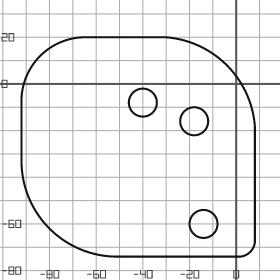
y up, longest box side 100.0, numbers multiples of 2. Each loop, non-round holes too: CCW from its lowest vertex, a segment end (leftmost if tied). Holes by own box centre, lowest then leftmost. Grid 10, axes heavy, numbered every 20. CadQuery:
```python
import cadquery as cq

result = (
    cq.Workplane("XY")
    .moveTo(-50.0, -74.0)
    .lineTo(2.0, -74.0)
    .threePointArc((6.0, -72.0), (8.0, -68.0))
    .lineTo(8.0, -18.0)
    .threePointArc((-4.0, 8.0), (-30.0, 20.0))
    .lineTo(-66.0, 20.0)
    .threePointArc((-84.0, 12.0), (-92.0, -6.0))
    .lineTo(-92.0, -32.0)
    .threePointArc((-80.0, -62.0), (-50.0, -74.0))
    .close()
    .moveTo(-14.0, -60.0)
    .circle(6.0)
    .moveTo(-18.0, -16.0)
    .circle(6.0)
    .moveTo(-40.0, -8.0)
    .circle(6.0)
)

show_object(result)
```